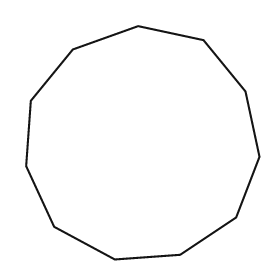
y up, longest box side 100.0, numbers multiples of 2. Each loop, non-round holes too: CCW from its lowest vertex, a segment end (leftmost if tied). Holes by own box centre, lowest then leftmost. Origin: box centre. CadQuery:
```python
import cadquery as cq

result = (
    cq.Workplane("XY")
    .moveTo(-12.0, -50.0)
    .lineTo(16.0, -48.0)
    .lineTo(40.0, -32.0)
    .lineTo(50.0, -6.0)
    .lineTo(44.0, 22.0)
    .lineTo(26.0, 44.0)
    .lineTo(-2.0, 50.0)
    .lineTo(-30.0, 40.0)
    .lineTo(-48.0, 18.0)
    .lineTo(-50.0, -10.0)
    .lineTo(-38.0, -36.0)
    .close()
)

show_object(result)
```